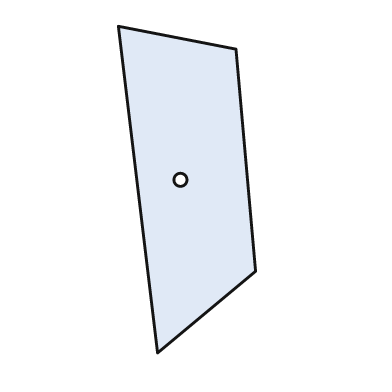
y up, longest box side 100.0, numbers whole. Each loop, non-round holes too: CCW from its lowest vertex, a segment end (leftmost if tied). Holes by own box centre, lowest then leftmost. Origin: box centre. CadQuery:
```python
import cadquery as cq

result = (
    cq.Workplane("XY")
    .moveTo(-9.0, -50.0)
    .lineTo(21.0, -25.0)
    .lineTo(15.0, 43.0)
    .lineTo(-21.0, 50.0)
    .close()
    .moveTo(-2.0, 3.0)
    .circle(2.0)
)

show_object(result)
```